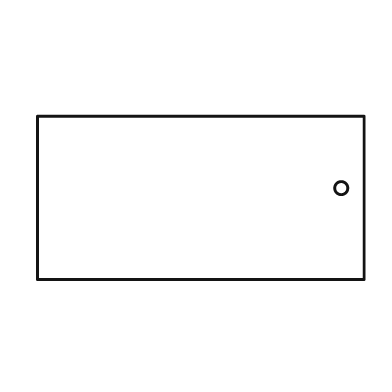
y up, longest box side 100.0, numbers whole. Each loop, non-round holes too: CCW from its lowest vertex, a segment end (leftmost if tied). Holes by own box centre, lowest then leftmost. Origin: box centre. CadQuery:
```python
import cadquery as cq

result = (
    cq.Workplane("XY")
    .moveTo(-50.0, -25.0)
    .lineTo(50.0, -25.0)
    .lineTo(50.0, 25.0)
    .lineTo(-50.0, 25.0)
    .close()
    .moveTo(43.0, 3.0)
    .circle(2.0)
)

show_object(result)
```